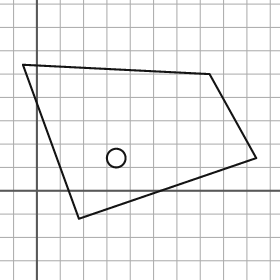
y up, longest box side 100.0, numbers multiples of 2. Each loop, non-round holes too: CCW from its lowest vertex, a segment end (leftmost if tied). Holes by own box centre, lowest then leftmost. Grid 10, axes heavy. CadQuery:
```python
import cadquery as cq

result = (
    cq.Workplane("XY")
    .moveTo(18.0, -12.0)
    .lineTo(94.0, 14.0)
    .lineTo(74.0, 50.0)
    .lineTo(-6.0, 54.0)
    .close()
    .moveTo(34.0, 14.0)
    .circle(4.0)
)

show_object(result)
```